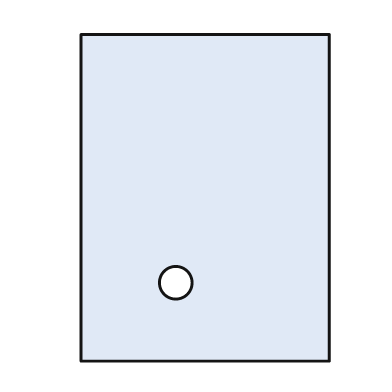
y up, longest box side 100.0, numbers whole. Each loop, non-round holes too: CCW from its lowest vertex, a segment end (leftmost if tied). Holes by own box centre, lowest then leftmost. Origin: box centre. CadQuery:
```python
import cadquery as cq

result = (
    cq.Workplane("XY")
    .moveTo(-38.0, -50.0)
    .lineTo(38.0, -50.0)
    .lineTo(38.0, 50.0)
    .lineTo(-38.0, 50.0)
    .close()
    .moveTo(-9.0, -26.0)
    .circle(5.0)
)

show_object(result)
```